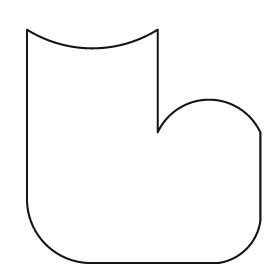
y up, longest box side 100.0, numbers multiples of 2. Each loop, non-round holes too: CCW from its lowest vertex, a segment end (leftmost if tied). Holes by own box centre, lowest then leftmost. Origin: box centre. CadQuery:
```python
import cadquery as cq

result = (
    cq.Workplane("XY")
    .moveTo(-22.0, -50.0)
    .lineTo(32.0, -50.0)
    .threePointArc((44.0, -44.0), (50.0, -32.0))
    .lineTo(50.0, 6.0)
    .threePointArc((28.0, 20.0), (6.0, 6.0))
    .lineTo(6.0, 50.0)
    .threePointArc((-22.0, 42.0), (-50.0, 50.0))
    .lineTo(-50.0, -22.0)
    .threePointArc((-42.0, -42.0), (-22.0, -50.0))
    .close()
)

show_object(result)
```